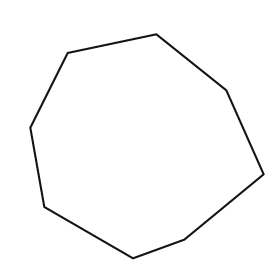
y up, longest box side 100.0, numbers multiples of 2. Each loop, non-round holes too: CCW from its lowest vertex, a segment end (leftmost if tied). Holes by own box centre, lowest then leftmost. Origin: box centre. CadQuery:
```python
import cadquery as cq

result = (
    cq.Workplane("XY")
    .moveTo(-6.0, -48.0)
    .lineTo(16.0, -40.0)
    .lineTo(50.0, -12.0)
    .lineTo(34.0, 24.0)
    .lineTo(4.0, 48.0)
    .lineTo(-34.0, 40.0)
    .lineTo(-50.0, 8.0)
    .lineTo(-44.0, -26.0)
    .close()
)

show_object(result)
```